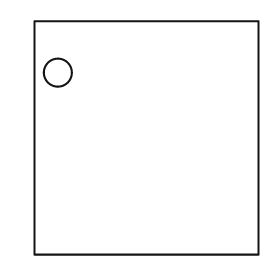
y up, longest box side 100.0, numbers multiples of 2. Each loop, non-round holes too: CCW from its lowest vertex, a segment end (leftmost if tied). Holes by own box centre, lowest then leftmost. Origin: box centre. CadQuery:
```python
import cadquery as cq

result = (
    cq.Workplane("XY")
    .moveTo(-48.0, -50.0)
    .lineTo(48.0, -50.0)
    .lineTo(48.0, 50.0)
    .lineTo(-48.0, 50.0)
    .close()
    .moveTo(-38.0, 28.0)
    .circle(6.0)
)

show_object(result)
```